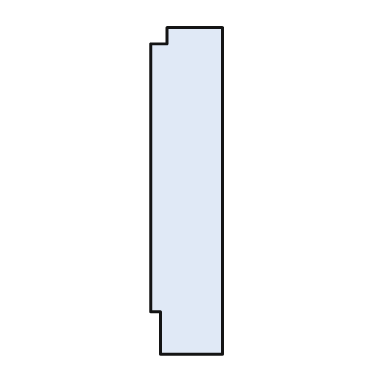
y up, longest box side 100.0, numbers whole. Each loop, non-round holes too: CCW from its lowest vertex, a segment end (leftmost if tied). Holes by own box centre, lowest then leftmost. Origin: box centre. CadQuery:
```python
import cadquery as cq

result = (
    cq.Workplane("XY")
    .moveTo(-8.0, -50.0)
    .lineTo(11.0, -50.0)
    .lineTo(11.0, 50.0)
    .lineTo(-6.0, 50.0)
    .lineTo(-6.0, 45.0)
    .lineTo(-11.0, 45.0)
    .lineTo(-11.0, -37.0)
    .lineTo(-8.0, -37.0)
    .close()
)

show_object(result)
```